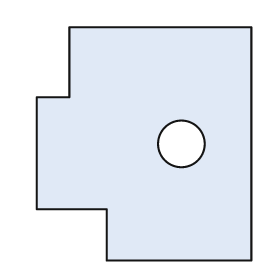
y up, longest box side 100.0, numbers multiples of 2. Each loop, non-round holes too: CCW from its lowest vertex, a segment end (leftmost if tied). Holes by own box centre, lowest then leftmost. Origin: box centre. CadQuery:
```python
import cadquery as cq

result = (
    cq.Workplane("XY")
    .moveTo(-16.0, -50.0)
    .lineTo(46.0, -50.0)
    .lineTo(46.0, 50.0)
    .lineTo(-32.0, 50.0)
    .lineTo(-32.0, 20.0)
    .lineTo(-46.0, 20.0)
    .lineTo(-46.0, -28.0)
    .lineTo(-16.0, -28.0)
    .close()
    .moveTo(16.0, 0.0)
    .circle(10.0)
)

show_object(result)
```